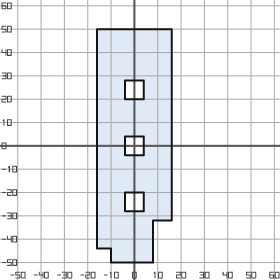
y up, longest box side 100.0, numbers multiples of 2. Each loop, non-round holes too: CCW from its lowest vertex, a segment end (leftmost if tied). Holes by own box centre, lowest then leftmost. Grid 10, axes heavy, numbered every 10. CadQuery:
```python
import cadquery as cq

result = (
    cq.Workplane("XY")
    .moveTo(-10.0, -50.0)
    .lineTo(8.0, -50.0)
    .lineTo(8.0, -32.0)
    .lineTo(16.0, -32.0)
    .lineTo(16.0, 50.0)
    .lineTo(-16.0, 50.0)
    .lineTo(-16.0, -44.0)
    .lineTo(-10.0, -44.0)
    .close()
    .moveTo(-4.0, -28.0)
    .lineTo(4.0, -28.0)
    .lineTo(4.0, -20.0)
    .lineTo(-4.0, -20.0)
    .close()
    .moveTo(-4.0, -4.0)
    .lineTo(4.0, -4.0)
    .lineTo(4.0, 4.0)
    .lineTo(-4.0, 4.0)
    .close()
    .moveTo(-4.0, 20.0)
    .lineTo(4.0, 20.0)
    .lineTo(4.0, 28.0)
    .lineTo(-4.0, 28.0)
    .close()
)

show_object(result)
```